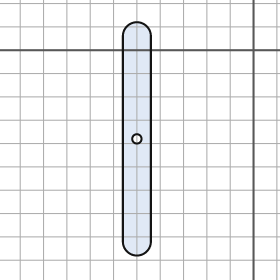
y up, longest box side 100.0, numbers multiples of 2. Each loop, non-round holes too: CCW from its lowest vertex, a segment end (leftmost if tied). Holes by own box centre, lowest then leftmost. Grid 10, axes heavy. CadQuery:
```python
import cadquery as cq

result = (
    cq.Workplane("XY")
    .moveTo(-56.0, -82.0)
    .threePointArc((-50.0, -88.0), (-44.0, -82.0))
    .lineTo(-44.0, 6.0)
    .threePointArc((-50.0, 12.0), (-56.0, 6.0))
    .close()
    .moveTo(-50.0, -38.0)
    .circle(2.0)
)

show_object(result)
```